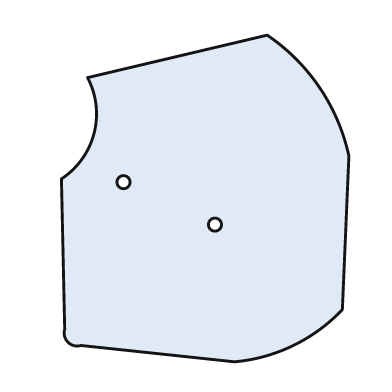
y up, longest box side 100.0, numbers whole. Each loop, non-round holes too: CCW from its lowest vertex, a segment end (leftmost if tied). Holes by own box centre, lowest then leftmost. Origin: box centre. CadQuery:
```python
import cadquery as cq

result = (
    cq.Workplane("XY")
    .moveTo(9.0, -50.0)
    .threePointArc((27.0, -45.0), (42.0, -34.0))
    .lineTo(44.0, 13.0)
    .threePointArc((35.0, 34.0), (19.0, 50.0))
    .lineTo(-36.0, 37.0)
    .threePointArc((-34.0, 20.0), (-44.0, 6.0))
    .lineTo(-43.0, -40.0)
    .threePointArc((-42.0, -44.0), (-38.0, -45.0))
    .close()
    .moveTo(3.0, -8.0)
    .circle(2.0)
    .moveTo(-25.0, 5.0)
    .circle(2.0)
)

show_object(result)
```